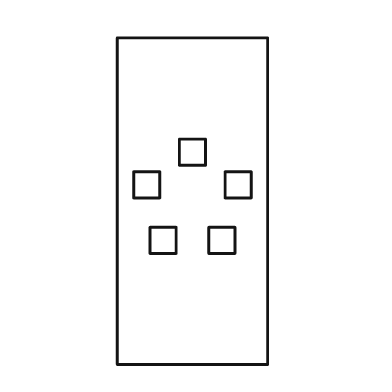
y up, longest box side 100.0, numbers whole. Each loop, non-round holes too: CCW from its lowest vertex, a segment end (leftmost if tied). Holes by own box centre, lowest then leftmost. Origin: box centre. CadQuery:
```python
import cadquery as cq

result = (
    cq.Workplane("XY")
    .moveTo(-23.0, -50.0)
    .lineTo(23.0, -50.0)
    .lineTo(23.0, 50.0)
    .lineTo(-23.0, 50.0)
    .close()
    .moveTo(-13.0, -16.0)
    .lineTo(-5.0, -16.0)
    .lineTo(-5.0, -8.0)
    .lineTo(-13.0, -8.0)
    .close()
    .moveTo(5.0, -16.0)
    .lineTo(13.0, -16.0)
    .lineTo(13.0, -8.0)
    .lineTo(5.0, -8.0)
    .close()
    .moveTo(-18.0, 1.0)
    .lineTo(-10.0, 1.0)
    .lineTo(-10.0, 9.0)
    .lineTo(-18.0, 9.0)
    .close()
    .moveTo(10.0, 1.0)
    .lineTo(18.0, 1.0)
    .lineTo(18.0, 9.0)
    .lineTo(10.0, 9.0)
    .close()
    .moveTo(-4.0, 11.0)
    .lineTo(4.0, 11.0)
    .lineTo(4.0, 19.0)
    .lineTo(-4.0, 19.0)
    .close()
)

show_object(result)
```